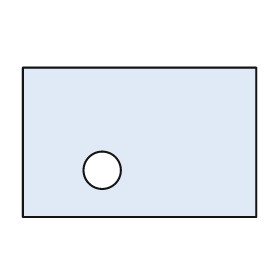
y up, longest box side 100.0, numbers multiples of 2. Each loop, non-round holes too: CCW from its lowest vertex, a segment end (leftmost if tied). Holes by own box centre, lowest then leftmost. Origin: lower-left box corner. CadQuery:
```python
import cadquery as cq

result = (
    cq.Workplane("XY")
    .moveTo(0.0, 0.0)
    .lineTo(100.0, 0.0)
    .lineTo(100.0, 64.0)
    .lineTo(0.0, 64.0)
    .close()
    .moveTo(34.0, 20.0)
    .circle(8.0)
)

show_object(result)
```